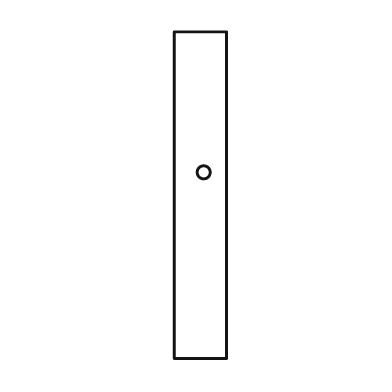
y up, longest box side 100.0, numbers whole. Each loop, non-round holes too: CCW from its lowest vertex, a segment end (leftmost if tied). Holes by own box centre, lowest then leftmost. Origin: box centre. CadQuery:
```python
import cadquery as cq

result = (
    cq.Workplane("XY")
    .moveTo(-8.0, -50.0)
    .lineTo(8.0, -50.0)
    .lineTo(8.0, 50.0)
    .lineTo(-8.0, 50.0)
    .close()
    .moveTo(1.0, 7.0)
    .circle(2.0)
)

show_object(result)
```